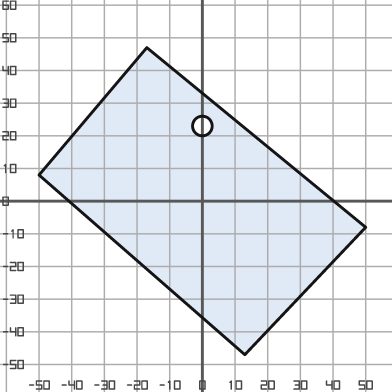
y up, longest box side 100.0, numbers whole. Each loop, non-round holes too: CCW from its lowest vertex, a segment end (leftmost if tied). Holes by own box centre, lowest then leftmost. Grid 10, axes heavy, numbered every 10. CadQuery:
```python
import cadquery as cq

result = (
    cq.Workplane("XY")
    .moveTo(13.0, -47.0)
    .lineTo(50.0, -8.0)
    .lineTo(-17.0, 47.0)
    .lineTo(-50.0, 8.0)
    .close()
    .moveTo(0.0, 23.0)
    .circle(3.0)
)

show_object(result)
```